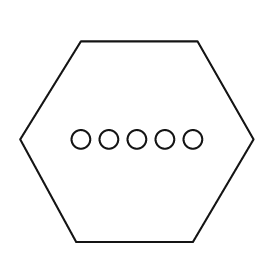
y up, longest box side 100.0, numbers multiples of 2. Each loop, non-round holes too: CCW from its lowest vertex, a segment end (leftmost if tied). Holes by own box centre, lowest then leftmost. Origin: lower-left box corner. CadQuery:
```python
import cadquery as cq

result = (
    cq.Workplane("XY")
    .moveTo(24.0, 0.0)
    .lineTo(74.0, 0.0)
    .lineTo(100.0, 44.0)
    .lineTo(76.0, 86.0)
    .lineTo(26.0, 86.0)
    .lineTo(0.0, 44.0)
    .close()
    .moveTo(26.0, 44.0)
    .circle(4.0)
    .moveTo(38.0, 44.0)
    .circle(4.0)
    .moveTo(50.0, 44.0)
    .circle(4.0)
    .moveTo(62.0, 44.0)
    .circle(4.0)
    .moveTo(74.0, 44.0)
    .circle(4.0)
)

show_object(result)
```